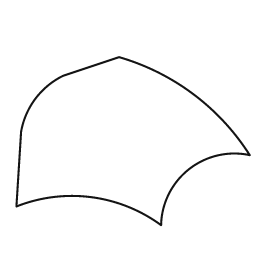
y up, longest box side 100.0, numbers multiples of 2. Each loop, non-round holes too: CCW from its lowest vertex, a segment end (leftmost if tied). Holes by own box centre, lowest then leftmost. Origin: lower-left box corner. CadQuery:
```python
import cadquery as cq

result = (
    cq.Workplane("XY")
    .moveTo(62.0, 0.0)
    .threePointArc((74.0, 24.0), (100.0, 30.0))
    .threePointArc((76.0, 56.0), (44.0, 72.0))
    .lineTo(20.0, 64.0)
    .threePointArc((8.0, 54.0), (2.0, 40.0))
    .lineTo(0.0, 8.0)
    .threePointArc((32.0, 12.0), (62.0, 0.0))
    .close()
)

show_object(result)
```